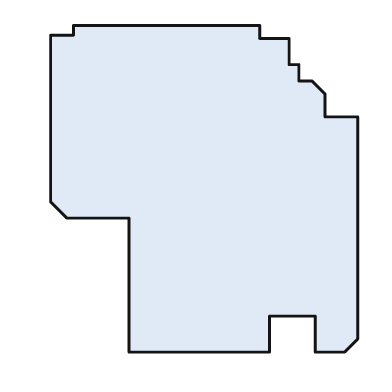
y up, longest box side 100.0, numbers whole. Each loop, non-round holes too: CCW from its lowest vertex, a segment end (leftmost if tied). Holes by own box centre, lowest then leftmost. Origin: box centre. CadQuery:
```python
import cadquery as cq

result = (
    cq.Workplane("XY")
    .moveTo(-23.0, -50.0)
    .lineTo(20.0, -50.0)
    .lineTo(20.0, -39.0)
    .lineTo(34.0, -39.0)
    .lineTo(34.0, -50.0)
    .lineTo(43.0, -50.0)
    .lineTo(47.0, -46.0)
    .lineTo(47.0, 22.0)
    .lineTo(37.0, 22.0)
    .lineTo(37.0, 29.0)
    .lineTo(33.0, 33.0)
    .lineTo(29.0, 33.0)
    .lineTo(29.0, 38.0)
    .lineTo(26.0, 38.0)
    .lineTo(26.0, 46.0)
    .lineTo(17.0, 46.0)
    .lineTo(17.0, 50.0)
    .lineTo(-40.0, 50.0)
    .lineTo(-40.0, 47.0)
    .lineTo(-47.0, 47.0)
    .lineTo(-47.0, -4.0)
    .lineTo(-42.0, -9.0)
    .lineTo(-23.0, -9.0)
    .close()
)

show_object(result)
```